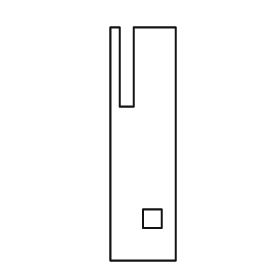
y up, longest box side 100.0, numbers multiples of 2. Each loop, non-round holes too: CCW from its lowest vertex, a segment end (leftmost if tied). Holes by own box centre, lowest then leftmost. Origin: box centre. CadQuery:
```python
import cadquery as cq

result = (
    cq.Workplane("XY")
    .moveTo(-14.0, -50.0)
    .lineTo(14.0, -50.0)
    .lineTo(14.0, 50.0)
    .lineTo(-4.0, 50.0)
    .lineTo(-4.0, 16.0)
    .lineTo(-10.0, 16.0)
    .lineTo(-10.0, 50.0)
    .lineTo(-14.0, 50.0)
    .close()
    .moveTo(0.0, -36.0)
    .lineTo(8.0, -36.0)
    .lineTo(8.0, -28.0)
    .lineTo(0.0, -28.0)
    .close()
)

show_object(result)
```